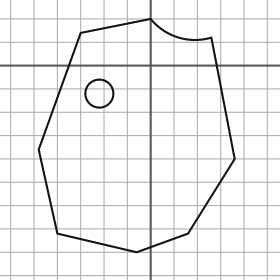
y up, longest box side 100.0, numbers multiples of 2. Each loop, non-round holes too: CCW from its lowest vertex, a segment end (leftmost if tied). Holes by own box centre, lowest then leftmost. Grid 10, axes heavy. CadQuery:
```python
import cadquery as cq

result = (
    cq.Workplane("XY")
    .moveTo(-6.0, -80.0)
    .lineTo(16.0, -72.0)
    .lineTo(36.0, -40.0)
    .lineTo(26.0, 12.0)
    .threePointArc((12.0, 12.0), (0.0, 20.0))
    .lineTo(-30.0, 14.0)
    .lineTo(-48.0, -36.0)
    .lineTo(-40.0, -72.0)
    .close()
    .moveTo(-22.0, -12.0)
    .circle(6.0)
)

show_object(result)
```